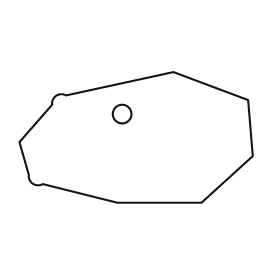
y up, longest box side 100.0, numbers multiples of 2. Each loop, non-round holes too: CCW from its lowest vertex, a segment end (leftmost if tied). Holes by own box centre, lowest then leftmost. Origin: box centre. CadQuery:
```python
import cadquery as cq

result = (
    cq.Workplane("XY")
    .moveTo(-8.0, -28.0)
    .lineTo(28.0, -28.0)
    .lineTo(50.0, -8.0)
    .lineTo(48.0, 16.0)
    .lineTo(16.0, 28.0)
    .lineTo(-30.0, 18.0)
    .threePointArc((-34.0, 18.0), (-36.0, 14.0))
    .lineTo(-50.0, -2.0)
    .lineTo(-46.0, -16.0)
    .threePointArc((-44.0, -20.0), (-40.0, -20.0))
    .close()
    .moveTo(-6.0, 10.0)
    .circle(4.0)
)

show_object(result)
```